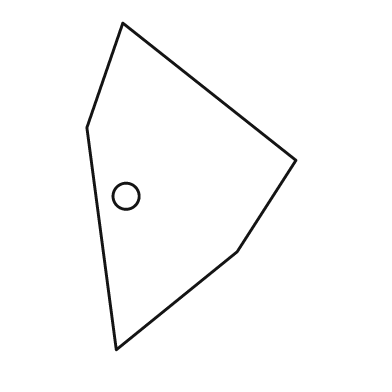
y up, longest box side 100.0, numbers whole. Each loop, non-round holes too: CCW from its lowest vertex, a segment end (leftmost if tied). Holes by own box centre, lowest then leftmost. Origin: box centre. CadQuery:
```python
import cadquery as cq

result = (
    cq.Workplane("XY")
    .moveTo(-23.0, -50.0)
    .lineTo(14.0, -20.0)
    .lineTo(32.0, 8.0)
    .lineTo(-21.0, 50.0)
    .lineTo(-32.0, 18.0)
    .close()
    .moveTo(-20.0, -3.0)
    .circle(4.0)
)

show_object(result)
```